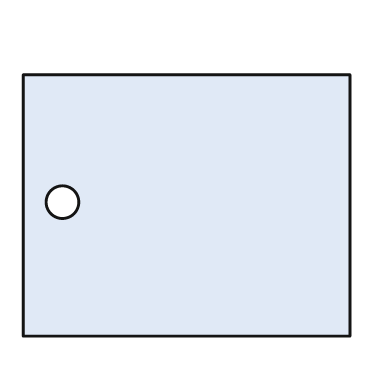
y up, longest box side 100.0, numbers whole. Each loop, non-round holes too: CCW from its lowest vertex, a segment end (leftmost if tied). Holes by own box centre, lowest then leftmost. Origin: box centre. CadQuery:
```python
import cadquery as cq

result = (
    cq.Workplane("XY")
    .moveTo(-50.0, -40.0)
    .lineTo(50.0, -40.0)
    .lineTo(50.0, 40.0)
    .lineTo(-50.0, 40.0)
    .close()
    .moveTo(-38.0, 1.0)
    .circle(5.0)
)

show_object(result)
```